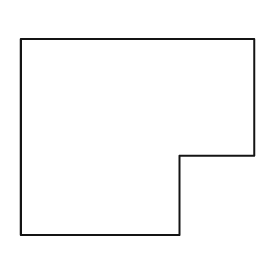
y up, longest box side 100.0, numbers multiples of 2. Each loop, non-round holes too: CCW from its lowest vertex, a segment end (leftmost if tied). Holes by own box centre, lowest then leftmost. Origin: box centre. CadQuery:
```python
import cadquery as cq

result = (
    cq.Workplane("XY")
    .moveTo(-50.0, -42.0)
    .lineTo(18.0, -42.0)
    .lineTo(18.0, -8.0)
    .lineTo(50.0, -8.0)
    .lineTo(50.0, 42.0)
    .lineTo(-50.0, 42.0)
    .close()
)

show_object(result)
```